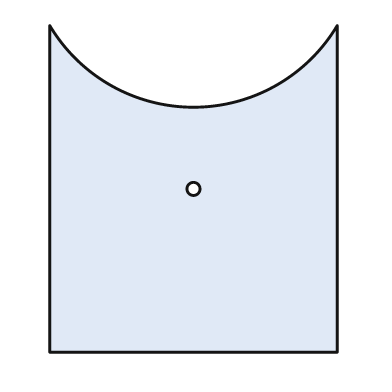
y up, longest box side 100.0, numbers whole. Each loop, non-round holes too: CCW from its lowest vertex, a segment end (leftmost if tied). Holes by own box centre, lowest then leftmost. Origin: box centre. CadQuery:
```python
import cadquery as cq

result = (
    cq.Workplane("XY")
    .moveTo(-44.0, -50.0)
    .lineTo(44.0, -50.0)
    .lineTo(44.0, 50.0)
    .threePointArc((0.0, 25.0), (-44.0, 50.0))
    .close()
    .moveTo(0.0, 0.0)
    .circle(2.0)
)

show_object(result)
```